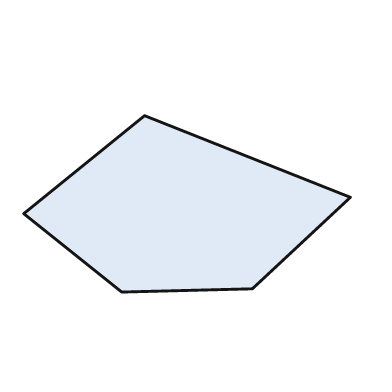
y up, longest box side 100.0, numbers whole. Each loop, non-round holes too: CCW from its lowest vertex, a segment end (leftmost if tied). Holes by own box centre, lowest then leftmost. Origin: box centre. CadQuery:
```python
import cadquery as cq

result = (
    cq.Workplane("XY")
    .moveTo(-20.0, -27.0)
    .lineTo(20.0, -26.0)
    .lineTo(50.0, 2.0)
    .lineTo(-13.0, 27.0)
    .lineTo(-50.0, -3.0)
    .close()
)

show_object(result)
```